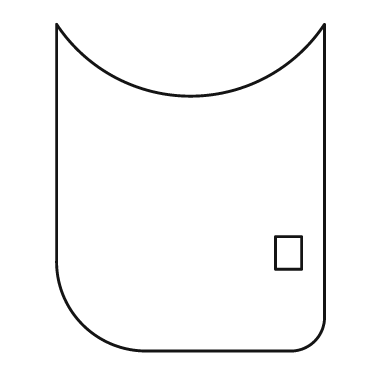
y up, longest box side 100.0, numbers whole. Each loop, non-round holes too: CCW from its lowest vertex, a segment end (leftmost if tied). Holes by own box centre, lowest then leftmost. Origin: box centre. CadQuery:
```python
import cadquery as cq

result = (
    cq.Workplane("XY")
    .moveTo(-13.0, -50.0)
    .lineTo(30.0, -50.0)
    .threePointArc((38.0, -47.0), (41.0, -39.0))
    .lineTo(41.0, 50.0)
    .threePointArc((0.0, 28.0), (-41.0, 50.0))
    .lineTo(-41.0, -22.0)
    .threePointArc((-33.0, -42.0), (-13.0, -50.0))
    .close()
    .moveTo(26.0, -25.0)
    .lineTo(34.0, -25.0)
    .lineTo(34.0, -15.0)
    .lineTo(26.0, -15.0)
    .close()
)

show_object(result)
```